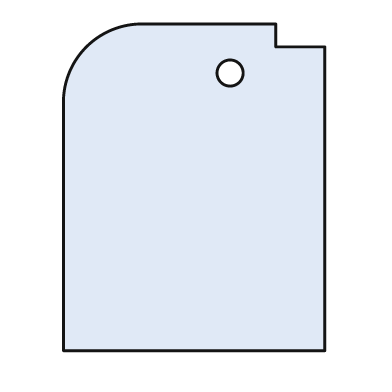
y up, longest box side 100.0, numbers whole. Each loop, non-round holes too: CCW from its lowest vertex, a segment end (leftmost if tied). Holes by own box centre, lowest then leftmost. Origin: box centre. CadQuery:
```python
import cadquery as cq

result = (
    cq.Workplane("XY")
    .moveTo(-40.0, -50.0)
    .lineTo(40.0, -50.0)
    .lineTo(40.0, 43.0)
    .lineTo(25.0, 43.0)
    .lineTo(25.0, 50.0)
    .lineTo(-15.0, 50.0)
    .threePointArc((-33.0, 43.0), (-40.0, 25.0))
    .close()
    .moveTo(11.0, 35.0)
    .circle(4.0)
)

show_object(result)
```